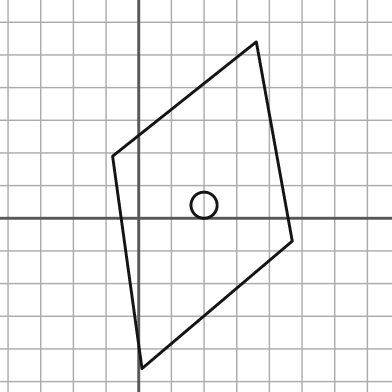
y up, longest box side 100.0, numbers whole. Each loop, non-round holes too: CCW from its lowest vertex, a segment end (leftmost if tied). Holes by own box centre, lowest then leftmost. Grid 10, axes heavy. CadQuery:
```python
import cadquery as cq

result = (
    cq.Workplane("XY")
    .moveTo(1.0, -46.0)
    .lineTo(47.0, -7.0)
    .lineTo(36.0, 54.0)
    .lineTo(-8.0, 19.0)
    .close()
    .moveTo(20.0, 4.0)
    .circle(4.0)
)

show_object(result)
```